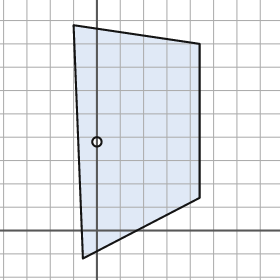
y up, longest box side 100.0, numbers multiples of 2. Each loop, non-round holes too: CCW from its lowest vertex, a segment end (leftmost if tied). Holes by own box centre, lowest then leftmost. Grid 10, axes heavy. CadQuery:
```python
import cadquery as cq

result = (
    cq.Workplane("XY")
    .moveTo(-6.0, -12.0)
    .lineTo(44.0, 14.0)
    .lineTo(44.0, 80.0)
    .lineTo(-10.0, 88.0)
    .close()
    .moveTo(0.0, 38.0)
    .circle(2.0)
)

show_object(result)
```